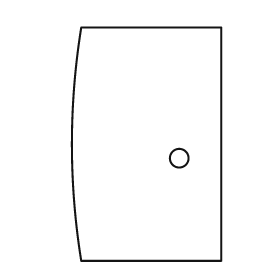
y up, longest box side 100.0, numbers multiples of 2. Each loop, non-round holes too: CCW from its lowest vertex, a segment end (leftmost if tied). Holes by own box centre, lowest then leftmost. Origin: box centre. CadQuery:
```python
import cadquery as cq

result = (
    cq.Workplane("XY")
    .moveTo(-28.0, -50.0)
    .lineTo(32.0, -50.0)
    .lineTo(32.0, 50.0)
    .lineTo(-28.0, 50.0)
    .threePointArc((-32.0, 0.0), (-28.0, -50.0))
    .close()
    .moveTo(14.0, -6.0)
    .circle(4.0)
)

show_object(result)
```